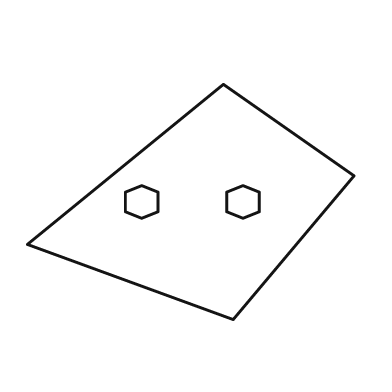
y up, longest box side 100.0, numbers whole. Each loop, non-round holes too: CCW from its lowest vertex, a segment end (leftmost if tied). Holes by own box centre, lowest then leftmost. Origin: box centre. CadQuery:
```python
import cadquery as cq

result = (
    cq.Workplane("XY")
    .moveTo(13.0, -36.0)
    .lineTo(50.0, 8.0)
    .lineTo(10.0, 36.0)
    .lineTo(-50.0, -13.0)
    .close()
    .moveTo(-15.0, -5.0)
    .lineTo(-10.0, -3.0)
    .lineTo(-10.0, 3.0)
    .lineTo(-15.0, 5.0)
    .lineTo(-20.0, 3.0)
    .lineTo(-20.0, -3.0)
    .close()
    .moveTo(16.0, -5.0)
    .lineTo(21.0, -3.0)
    .lineTo(21.0, 3.0)
    .lineTo(16.0, 5.0)
    .lineTo(11.0, 3.0)
    .lineTo(11.0, -3.0)
    .close()
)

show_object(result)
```